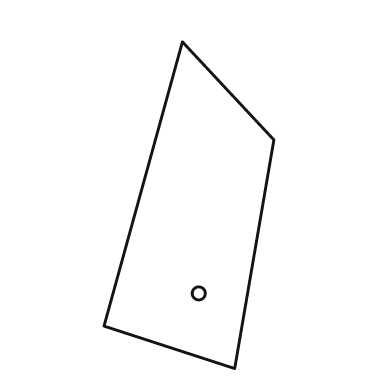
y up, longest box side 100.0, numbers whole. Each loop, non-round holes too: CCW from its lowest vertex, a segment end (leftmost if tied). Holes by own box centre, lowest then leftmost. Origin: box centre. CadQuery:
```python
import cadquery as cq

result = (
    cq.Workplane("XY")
    .moveTo(14.0, -50.0)
    .lineTo(26.0, 20.0)
    .lineTo(-2.0, 50.0)
    .lineTo(-26.0, -37.0)
    .close()
    .moveTo(3.0, -27.0)
    .circle(2.0)
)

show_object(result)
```